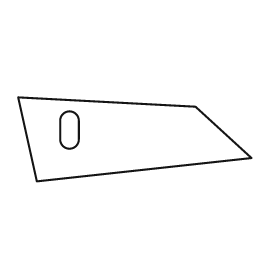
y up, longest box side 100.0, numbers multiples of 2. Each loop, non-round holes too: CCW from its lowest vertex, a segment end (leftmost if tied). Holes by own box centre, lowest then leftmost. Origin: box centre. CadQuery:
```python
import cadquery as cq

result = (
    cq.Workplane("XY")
    .moveTo(-42.0, -18.0)
    .lineTo(50.0, -8.0)
    .lineTo(26.0, 14.0)
    .lineTo(-50.0, 18.0)
    .close()
    .moveTo(-32.0, 0.0)
    .threePointArc((-28.0, -4.0), (-24.0, 0.0))
    .lineTo(-24.0, 8.0)
    .threePointArc((-28.0, 12.0), (-32.0, 8.0))
    .close()
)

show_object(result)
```